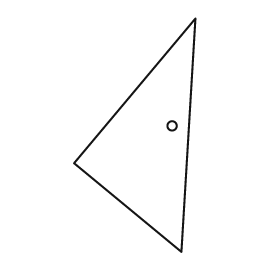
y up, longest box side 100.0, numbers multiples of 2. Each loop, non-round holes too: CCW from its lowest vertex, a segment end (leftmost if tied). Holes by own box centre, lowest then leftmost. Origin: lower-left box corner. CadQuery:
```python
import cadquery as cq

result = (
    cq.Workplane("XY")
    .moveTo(46.0, 0.0)
    .lineTo(52.0, 100.0)
    .lineTo(0.0, 38.0)
    .close()
    .moveTo(42.0, 54.0)
    .circle(2.0)
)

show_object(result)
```